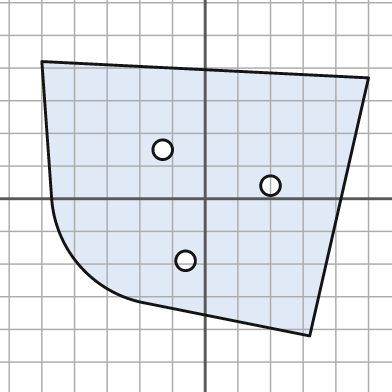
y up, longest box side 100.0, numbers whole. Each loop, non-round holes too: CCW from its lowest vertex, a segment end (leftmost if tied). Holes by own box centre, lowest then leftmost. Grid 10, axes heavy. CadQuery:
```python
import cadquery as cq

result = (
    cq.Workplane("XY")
    .moveTo(32.0, -42.0)
    .lineTo(50.0, 37.0)
    .lineTo(-50.0, 42.0)
    .lineTo(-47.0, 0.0)
    .threePointArc((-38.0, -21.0), (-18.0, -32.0))
    .close()
    .moveTo(-6.0, -19.0)
    .circle(3.0)
    .moveTo(20.0, 4.0)
    .circle(3.0)
    .moveTo(-13.0, 15.0)
    .circle(3.0)
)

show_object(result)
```